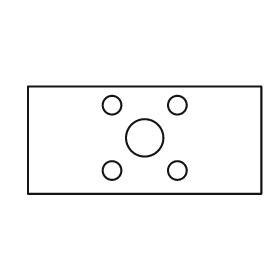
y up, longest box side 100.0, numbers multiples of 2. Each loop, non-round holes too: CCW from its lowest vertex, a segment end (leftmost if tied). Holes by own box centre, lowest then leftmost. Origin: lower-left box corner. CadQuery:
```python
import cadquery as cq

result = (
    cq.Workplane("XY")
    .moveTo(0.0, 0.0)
    .lineTo(100.0, 0.0)
    .lineTo(100.0, 46.0)
    .lineTo(0.0, 46.0)
    .close()
    .moveTo(36.0, 10.0)
    .circle(4.0)
    .moveTo(64.0, 10.0)
    .circle(4.0)
    .moveTo(50.0, 24.0)
    .circle(8.0)
    .moveTo(36.0, 38.0)
    .circle(4.0)
    .moveTo(64.0, 38.0)
    .circle(4.0)
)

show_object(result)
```